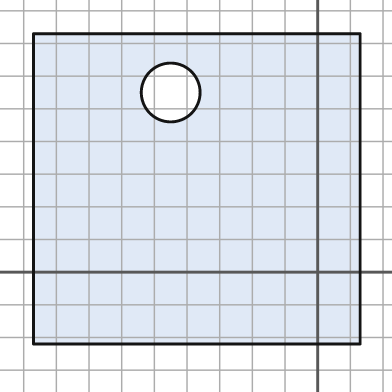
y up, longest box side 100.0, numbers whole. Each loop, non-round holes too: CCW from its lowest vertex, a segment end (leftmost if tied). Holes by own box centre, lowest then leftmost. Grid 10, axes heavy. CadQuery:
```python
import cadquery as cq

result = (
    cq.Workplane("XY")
    .moveTo(-87.0, -22.0)
    .lineTo(13.0, -22.0)
    .lineTo(13.0, 73.0)
    .lineTo(-87.0, 73.0)
    .close()
    .moveTo(-45.0, 55.0)
    .circle(9.0)
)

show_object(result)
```